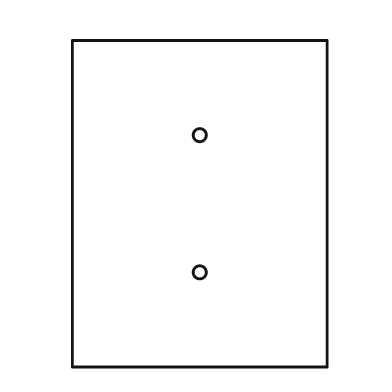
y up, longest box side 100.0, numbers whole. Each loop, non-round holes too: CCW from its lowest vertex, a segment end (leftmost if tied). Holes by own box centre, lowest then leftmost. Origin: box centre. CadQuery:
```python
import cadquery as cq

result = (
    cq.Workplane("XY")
    .moveTo(-39.0, -50.0)
    .lineTo(39.0, -50.0)
    .lineTo(39.0, 50.0)
    .lineTo(-39.0, 50.0)
    .close()
    .moveTo(0.0, -21.0)
    .circle(2.0)
    .moveTo(0.0, 21.0)
    .circle(2.0)
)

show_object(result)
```